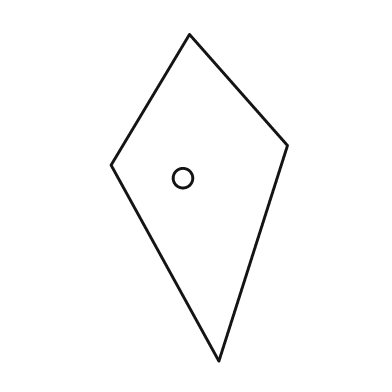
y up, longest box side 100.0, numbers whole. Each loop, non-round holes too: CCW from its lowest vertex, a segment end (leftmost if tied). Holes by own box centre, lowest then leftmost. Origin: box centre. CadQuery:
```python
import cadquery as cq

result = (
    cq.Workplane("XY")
    .moveTo(6.0, -50.0)
    .lineTo(27.0, 16.0)
    .lineTo(-3.0, 50.0)
    .lineTo(-27.0, 10.0)
    .close()
    .moveTo(-5.0, 6.0)
    .circle(3.0)
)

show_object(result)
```